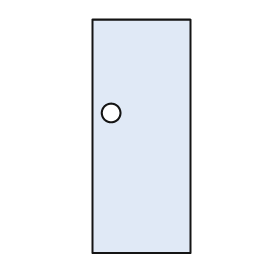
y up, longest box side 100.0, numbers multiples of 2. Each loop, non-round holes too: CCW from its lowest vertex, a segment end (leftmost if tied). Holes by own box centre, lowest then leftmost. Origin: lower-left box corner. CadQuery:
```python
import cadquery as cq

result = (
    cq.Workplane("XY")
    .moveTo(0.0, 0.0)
    .lineTo(42.0, 0.0)
    .lineTo(42.0, 100.0)
    .lineTo(0.0, 100.0)
    .close()
    .moveTo(8.0, 60.0)
    .circle(4.0)
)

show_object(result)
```